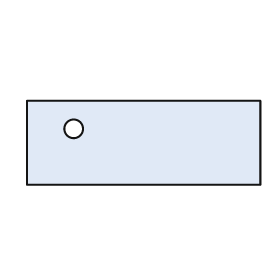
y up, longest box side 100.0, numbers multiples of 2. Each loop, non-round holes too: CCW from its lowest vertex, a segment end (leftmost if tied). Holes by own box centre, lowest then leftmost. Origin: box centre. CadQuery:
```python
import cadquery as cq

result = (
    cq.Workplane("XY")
    .moveTo(-50.0, -18.0)
    .lineTo(50.0, -18.0)
    .lineTo(50.0, 18.0)
    .lineTo(-50.0, 18.0)
    .close()
    .moveTo(-30.0, 6.0)
    .circle(4.0)
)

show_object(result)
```